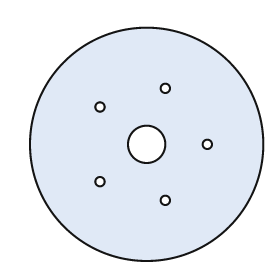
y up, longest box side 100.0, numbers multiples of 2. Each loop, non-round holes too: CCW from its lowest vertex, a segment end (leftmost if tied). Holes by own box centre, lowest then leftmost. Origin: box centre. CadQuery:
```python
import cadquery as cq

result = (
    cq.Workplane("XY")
    .moveTo(0.0, 0.0)
    .circle(50.0)
    .moveTo(8.0, -24.0)
    .circle(2.0)
    .moveTo(-20.0, -16.0)
    .circle(2.0)
    .moveTo(0.0, 0.0)
    .circle(8.0)
    .moveTo(26.0, 0.0)
    .circle(2.0)
    .moveTo(-20.0, 16.0)
    .circle(2.0)
    .moveTo(8.0, 24.0)
    .circle(2.0)
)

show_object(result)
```